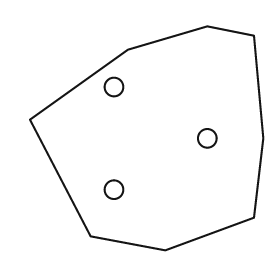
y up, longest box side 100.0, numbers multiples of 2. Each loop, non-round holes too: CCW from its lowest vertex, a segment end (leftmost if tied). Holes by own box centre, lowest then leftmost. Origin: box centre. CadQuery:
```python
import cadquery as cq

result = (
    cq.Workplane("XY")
    .moveTo(8.0, -48.0)
    .lineTo(46.0, -34.0)
    .lineTo(50.0, 0.0)
    .lineTo(46.0, 44.0)
    .lineTo(26.0, 48.0)
    .lineTo(-8.0, 38.0)
    .lineTo(-50.0, 8.0)
    .lineTo(-24.0, -42.0)
    .close()
    .moveTo(-14.0, -22.0)
    .circle(4.0)
    .moveTo(26.0, 0.0)
    .circle(4.0)
    .moveTo(-14.0, 22.0)
    .circle(4.0)
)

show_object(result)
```